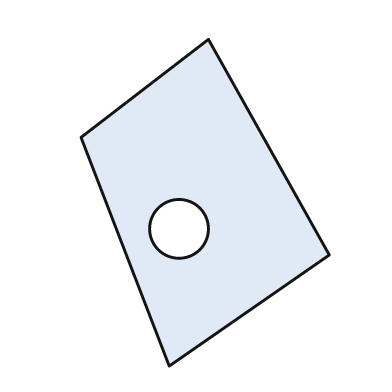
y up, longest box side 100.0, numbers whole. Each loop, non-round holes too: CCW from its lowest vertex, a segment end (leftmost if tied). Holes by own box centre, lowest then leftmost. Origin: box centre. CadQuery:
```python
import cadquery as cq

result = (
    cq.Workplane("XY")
    .moveTo(-11.0, -50.0)
    .lineTo(38.0, -16.0)
    .lineTo(1.0, 50.0)
    .lineTo(-38.0, 20.0)
    .close()
    .moveTo(-8.0, -8.0)
    .circle(9.0)
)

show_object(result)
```